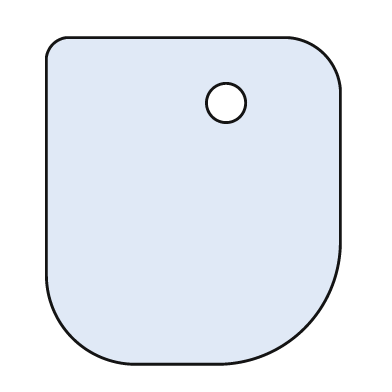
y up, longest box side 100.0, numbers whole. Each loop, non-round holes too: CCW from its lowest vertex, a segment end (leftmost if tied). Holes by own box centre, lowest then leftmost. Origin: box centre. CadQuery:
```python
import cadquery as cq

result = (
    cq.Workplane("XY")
    .moveTo(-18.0, -50.0)
    .lineTo(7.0, -50.0)
    .threePointArc((34.0, -39.0), (45.0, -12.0))
    .lineTo(45.0, 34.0)
    .threePointArc((40.0, 45.0), (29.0, 50.0))
    .lineTo(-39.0, 50.0)
    .threePointArc((-43.0, 48.0), (-45.0, 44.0))
    .lineTo(-45.0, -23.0)
    .threePointArc((-37.0, -42.0), (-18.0, -50.0))
    .close()
    .moveTo(10.0, 30.0)
    .circle(6.0)
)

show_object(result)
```